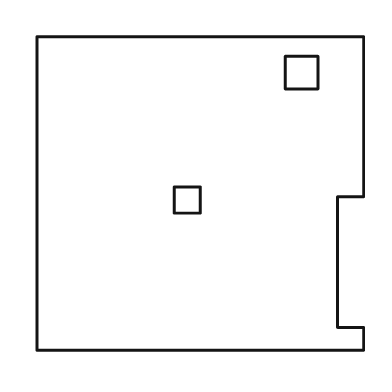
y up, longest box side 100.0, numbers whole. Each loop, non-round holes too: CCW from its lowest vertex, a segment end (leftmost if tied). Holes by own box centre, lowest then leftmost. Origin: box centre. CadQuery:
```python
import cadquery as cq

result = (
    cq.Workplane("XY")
    .moveTo(-50.0, -48.0)
    .lineTo(50.0, -48.0)
    .lineTo(50.0, -41.0)
    .lineTo(42.0, -41.0)
    .lineTo(42.0, -1.0)
    .lineTo(50.0, -1.0)
    .lineTo(50.0, 48.0)
    .lineTo(-50.0, 48.0)
    .close()
    .moveTo(-8.0, -6.0)
    .lineTo(0.0, -6.0)
    .lineTo(0.0, 2.0)
    .lineTo(-8.0, 2.0)
    .close()
    .moveTo(26.0, 32.0)
    .lineTo(36.0, 32.0)
    .lineTo(36.0, 42.0)
    .lineTo(26.0, 42.0)
    .close()
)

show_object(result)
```